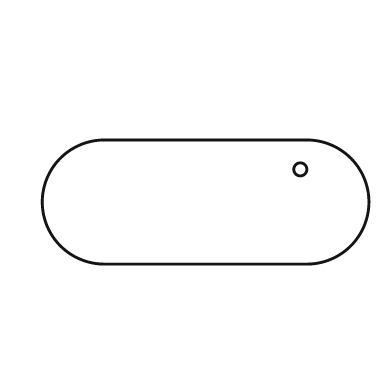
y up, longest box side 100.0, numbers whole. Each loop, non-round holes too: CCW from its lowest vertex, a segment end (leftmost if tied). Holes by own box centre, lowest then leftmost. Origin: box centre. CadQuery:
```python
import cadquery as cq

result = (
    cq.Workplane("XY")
    .moveTo(-31.0, -19.0)
    .lineTo(31.0, -19.0)
    .threePointArc((50.0, 0.0), (31.0, 19.0))
    .lineTo(-31.0, 19.0)
    .threePointArc((-50.0, 0.0), (-31.0, -19.0))
    .close()
    .moveTo(29.0, 10.0)
    .circle(2.0)
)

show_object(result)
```